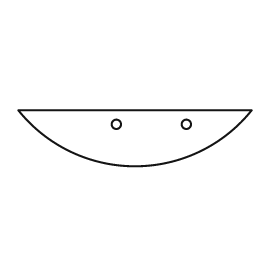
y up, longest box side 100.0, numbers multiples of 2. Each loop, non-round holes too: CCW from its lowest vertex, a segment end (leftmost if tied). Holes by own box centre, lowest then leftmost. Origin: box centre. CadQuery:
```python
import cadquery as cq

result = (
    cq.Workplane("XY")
    .moveTo(-50.0, 12.0)
    .threePointArc((0.0, -12.0), (50.0, 12.0))
    .close()
    .moveTo(-8.0, 6.0)
    .circle(2.0)
    .moveTo(22.0, 6.0)
    .circle(2.0)
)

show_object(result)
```